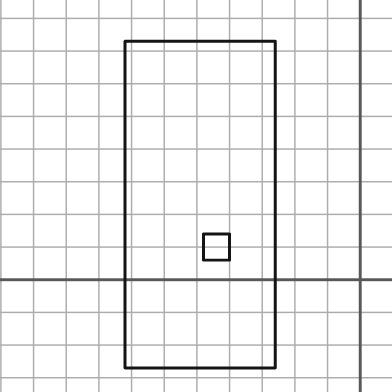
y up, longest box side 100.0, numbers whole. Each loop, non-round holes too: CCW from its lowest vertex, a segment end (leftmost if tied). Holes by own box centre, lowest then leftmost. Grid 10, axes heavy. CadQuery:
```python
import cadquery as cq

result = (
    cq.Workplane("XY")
    .moveTo(-72.0, -27.0)
    .lineTo(-26.0, -27.0)
    .lineTo(-26.0, 73.0)
    .lineTo(-72.0, 73.0)
    .close()
    .moveTo(-48.0, 6.0)
    .lineTo(-40.0, 6.0)
    .lineTo(-40.0, 14.0)
    .lineTo(-48.0, 14.0)
    .close()
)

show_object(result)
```